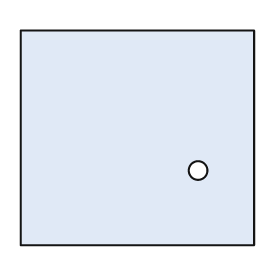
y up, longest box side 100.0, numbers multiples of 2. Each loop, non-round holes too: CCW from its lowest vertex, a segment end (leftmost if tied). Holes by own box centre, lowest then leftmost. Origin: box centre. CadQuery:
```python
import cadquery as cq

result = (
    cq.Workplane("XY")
    .moveTo(-50.0, -46.0)
    .lineTo(50.0, -46.0)
    .lineTo(50.0, 46.0)
    .lineTo(-50.0, 46.0)
    .close()
    .moveTo(26.0, -14.0)
    .circle(4.0)
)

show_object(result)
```